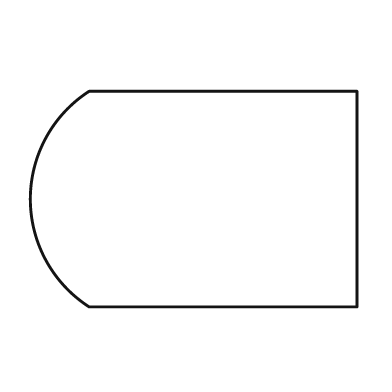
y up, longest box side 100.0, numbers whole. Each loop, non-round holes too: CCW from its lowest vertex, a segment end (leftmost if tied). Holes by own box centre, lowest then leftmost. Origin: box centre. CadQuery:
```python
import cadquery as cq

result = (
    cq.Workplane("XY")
    .moveTo(-32.0, -33.0)
    .lineTo(50.0, -33.0)
    .lineTo(50.0, 33.0)
    .lineTo(-32.0, 33.0)
    .threePointArc((-50.0, 0.0), (-32.0, -33.0))
    .close()
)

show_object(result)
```